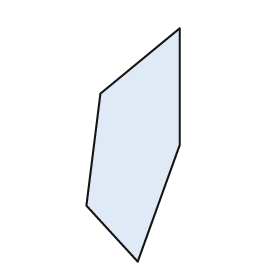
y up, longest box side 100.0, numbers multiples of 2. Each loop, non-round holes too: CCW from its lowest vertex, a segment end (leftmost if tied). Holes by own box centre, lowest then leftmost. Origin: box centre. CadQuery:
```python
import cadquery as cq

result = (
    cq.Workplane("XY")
    .moveTo(2.0, -50.0)
    .lineTo(20.0, 0.0)
    .lineTo(20.0, 50.0)
    .lineTo(-14.0, 22.0)
    .lineTo(-20.0, -26.0)
    .close()
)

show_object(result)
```